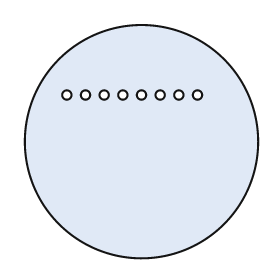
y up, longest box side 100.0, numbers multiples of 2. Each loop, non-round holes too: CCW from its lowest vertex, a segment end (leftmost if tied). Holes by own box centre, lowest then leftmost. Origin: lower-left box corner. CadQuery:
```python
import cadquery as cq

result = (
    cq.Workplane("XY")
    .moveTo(50.0, 50.0)
    .circle(50.0)
    .moveTo(18.0, 70.0)
    .circle(2.0)
    .moveTo(26.0, 70.0)
    .circle(2.0)
    .moveTo(34.0, 70.0)
    .circle(2.0)
    .moveTo(42.0, 70.0)
    .circle(2.0)
    .moveTo(50.0, 70.0)
    .circle(2.0)
    .moveTo(58.0, 70.0)
    .circle(2.0)
    .moveTo(66.0, 70.0)
    .circle(2.0)
    .moveTo(74.0, 70.0)
    .circle(2.0)
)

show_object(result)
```